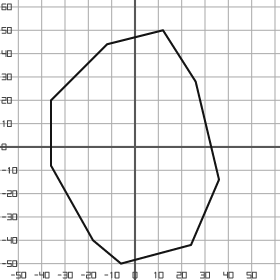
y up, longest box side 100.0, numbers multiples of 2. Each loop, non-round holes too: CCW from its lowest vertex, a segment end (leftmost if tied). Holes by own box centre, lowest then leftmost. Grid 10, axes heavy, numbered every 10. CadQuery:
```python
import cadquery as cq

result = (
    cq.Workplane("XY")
    .moveTo(-6.0, -50.0)
    .lineTo(24.0, -42.0)
    .lineTo(36.0, -14.0)
    .lineTo(26.0, 28.0)
    .lineTo(12.0, 50.0)
    .lineTo(-12.0, 44.0)
    .lineTo(-36.0, 20.0)
    .lineTo(-36.0, -8.0)
    .lineTo(-18.0, -40.0)
    .close()
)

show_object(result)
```